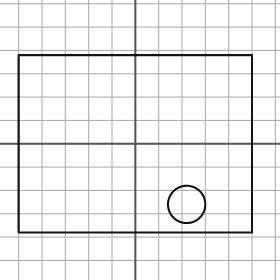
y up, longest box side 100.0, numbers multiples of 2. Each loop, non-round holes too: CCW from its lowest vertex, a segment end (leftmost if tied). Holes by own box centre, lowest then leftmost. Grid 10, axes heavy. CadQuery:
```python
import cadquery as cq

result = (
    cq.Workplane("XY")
    .moveTo(-50.0, -38.0)
    .lineTo(50.0, -38.0)
    .lineTo(50.0, 38.0)
    .lineTo(-50.0, 38.0)
    .close()
    .moveTo(22.0, -26.0)
    .circle(8.0)
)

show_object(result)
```